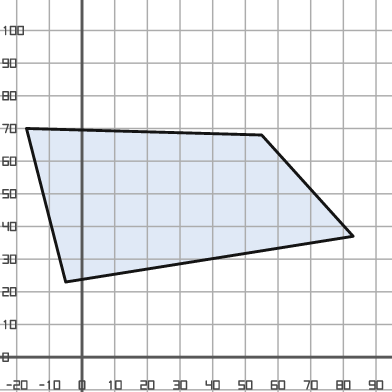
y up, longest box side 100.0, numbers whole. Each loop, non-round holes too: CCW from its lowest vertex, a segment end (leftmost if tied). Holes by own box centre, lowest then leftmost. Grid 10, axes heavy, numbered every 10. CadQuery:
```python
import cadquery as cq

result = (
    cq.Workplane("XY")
    .moveTo(-5.0, 23.0)
    .lineTo(83.0, 37.0)
    .lineTo(55.0, 68.0)
    .lineTo(-17.0, 70.0)
    .close()
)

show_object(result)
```